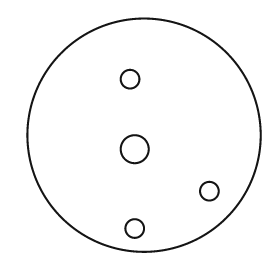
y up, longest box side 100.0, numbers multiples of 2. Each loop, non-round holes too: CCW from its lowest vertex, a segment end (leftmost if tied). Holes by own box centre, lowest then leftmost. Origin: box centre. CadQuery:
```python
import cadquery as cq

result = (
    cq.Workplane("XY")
    .moveTo(0.0, 0.0)
    .circle(50.0)
    .moveTo(-4.0, -40.0)
    .circle(4.0)
    .moveTo(28.0, -24.0)
    .circle(4.0)
    .moveTo(-4.0, -6.0)
    .circle(6.0)
    .moveTo(-6.0, 24.0)
    .circle(4.0)
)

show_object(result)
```